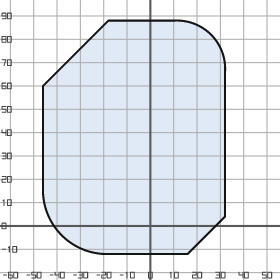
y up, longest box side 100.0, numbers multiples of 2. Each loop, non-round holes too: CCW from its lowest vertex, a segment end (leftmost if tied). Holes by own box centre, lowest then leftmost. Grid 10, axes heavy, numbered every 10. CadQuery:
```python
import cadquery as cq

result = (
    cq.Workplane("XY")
    .moveTo(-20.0, -12.0)
    .lineTo(16.0, -12.0)
    .lineTo(32.0, 4.0)
    .lineTo(32.0, 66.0)
    .threePointArc((26.0, 82.0), (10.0, 88.0))
    .lineTo(-18.0, 88.0)
    .lineTo(-46.0, 60.0)
    .lineTo(-46.0, 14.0)
    .threePointArc((-38.0, -4.0), (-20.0, -12.0))
    .close()
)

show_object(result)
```